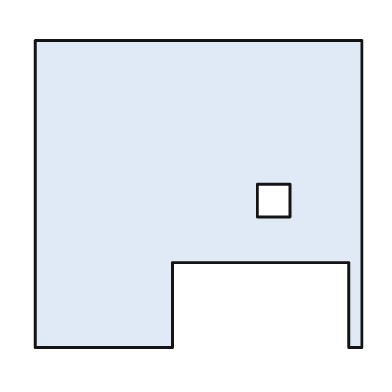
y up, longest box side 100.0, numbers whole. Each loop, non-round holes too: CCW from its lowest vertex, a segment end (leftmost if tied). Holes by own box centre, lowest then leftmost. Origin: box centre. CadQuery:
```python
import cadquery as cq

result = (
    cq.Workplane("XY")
    .moveTo(-50.0, -47.0)
    .lineTo(-8.0, -47.0)
    .lineTo(-8.0, -21.0)
    .lineTo(46.0, -21.0)
    .lineTo(46.0, -47.0)
    .lineTo(50.0, -47.0)
    .lineTo(50.0, 47.0)
    .lineTo(-50.0, 47.0)
    .close()
    .moveTo(18.0, -7.0)
    .lineTo(28.0, -7.0)
    .lineTo(28.0, 3.0)
    .lineTo(18.0, 3.0)
    .close()
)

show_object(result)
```